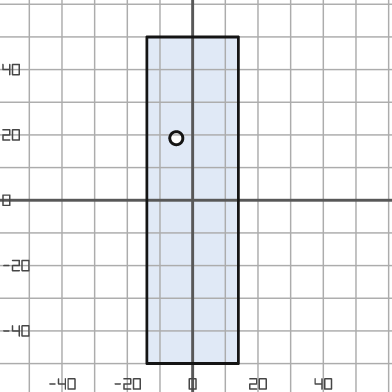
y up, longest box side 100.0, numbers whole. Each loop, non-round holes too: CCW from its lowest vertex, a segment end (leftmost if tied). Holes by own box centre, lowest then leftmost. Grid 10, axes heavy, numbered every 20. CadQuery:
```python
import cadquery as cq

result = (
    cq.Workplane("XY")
    .moveTo(-14.0, -50.0)
    .lineTo(14.0, -50.0)
    .lineTo(14.0, 50.0)
    .lineTo(-14.0, 50.0)
    .close()
    .moveTo(-5.0, 19.0)
    .circle(2.0)
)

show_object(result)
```